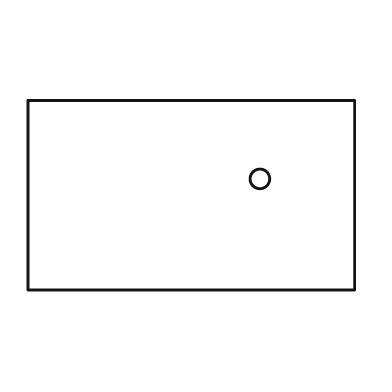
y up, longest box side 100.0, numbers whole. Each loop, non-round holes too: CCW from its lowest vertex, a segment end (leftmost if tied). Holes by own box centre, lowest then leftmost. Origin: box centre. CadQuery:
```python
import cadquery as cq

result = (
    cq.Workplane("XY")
    .moveTo(-50.0, -29.0)
    .lineTo(50.0, -29.0)
    .lineTo(50.0, 29.0)
    .lineTo(-50.0, 29.0)
    .close()
    .moveTo(21.0, 5.0)
    .circle(3.0)
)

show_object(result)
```